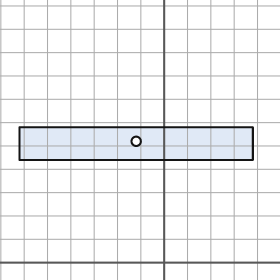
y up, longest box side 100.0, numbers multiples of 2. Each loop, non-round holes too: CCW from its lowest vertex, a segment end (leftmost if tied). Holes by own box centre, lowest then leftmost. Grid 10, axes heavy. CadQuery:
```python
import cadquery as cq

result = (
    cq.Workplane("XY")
    .moveTo(-62.0, 44.0)
    .lineTo(38.0, 44.0)
    .lineTo(38.0, 58.0)
    .lineTo(-62.0, 58.0)
    .close()
    .moveTo(-12.0, 52.0)
    .circle(2.0)
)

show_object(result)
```